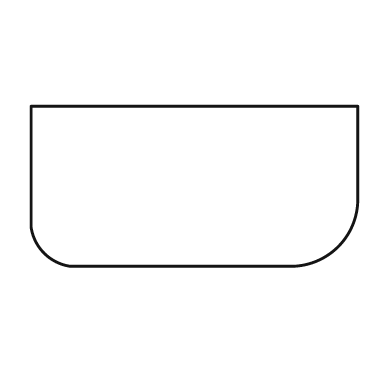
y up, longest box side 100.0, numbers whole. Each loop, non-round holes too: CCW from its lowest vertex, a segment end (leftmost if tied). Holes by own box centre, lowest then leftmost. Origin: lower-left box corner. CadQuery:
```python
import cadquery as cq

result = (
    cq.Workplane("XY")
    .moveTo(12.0, 0.0)
    .lineTo(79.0, 0.0)
    .threePointArc((94.0, 6.0), (100.0, 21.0))
    .lineTo(100.0, 49.0)
    .lineTo(0.0, 49.0)
    .lineTo(0.0, 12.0)
    .threePointArc((4.0, 4.0), (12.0, 0.0))
    .close()
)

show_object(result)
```